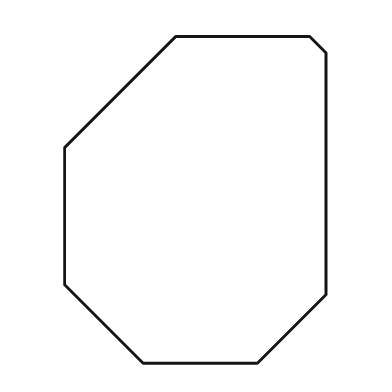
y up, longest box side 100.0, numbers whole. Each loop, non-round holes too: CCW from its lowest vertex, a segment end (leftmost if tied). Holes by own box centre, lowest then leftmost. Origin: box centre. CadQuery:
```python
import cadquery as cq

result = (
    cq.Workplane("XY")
    .moveTo(-16.0, -50.0)
    .lineTo(19.0, -50.0)
    .lineTo(40.0, -29.0)
    .lineTo(40.0, 45.0)
    .lineTo(35.0, 50.0)
    .lineTo(-6.0, 50.0)
    .lineTo(-40.0, 16.0)
    .lineTo(-40.0, -26.0)
    .close()
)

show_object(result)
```